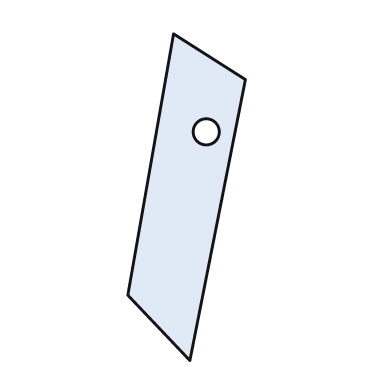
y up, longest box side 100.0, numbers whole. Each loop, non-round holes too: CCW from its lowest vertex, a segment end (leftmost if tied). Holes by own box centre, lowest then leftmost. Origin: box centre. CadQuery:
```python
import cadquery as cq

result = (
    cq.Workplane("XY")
    .moveTo(1.0, -50.0)
    .lineTo(18.0, 36.0)
    .lineTo(-4.0, 50.0)
    .lineTo(-18.0, -30.0)
    .close()
    .moveTo(6.0, 20.0)
    .circle(4.0)
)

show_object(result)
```